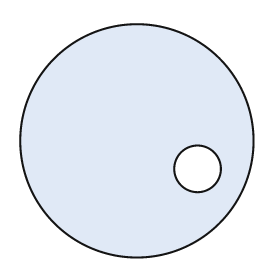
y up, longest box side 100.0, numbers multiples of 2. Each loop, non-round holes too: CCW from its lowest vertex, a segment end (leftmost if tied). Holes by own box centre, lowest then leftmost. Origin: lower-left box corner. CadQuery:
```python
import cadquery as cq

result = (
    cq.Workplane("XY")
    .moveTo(50.0, 50.0)
    .circle(50.0)
    .moveTo(76.0, 38.0)
    .circle(10.0)
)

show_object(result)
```